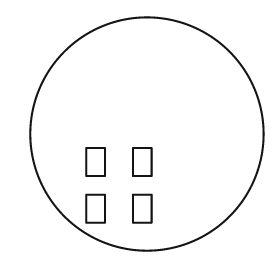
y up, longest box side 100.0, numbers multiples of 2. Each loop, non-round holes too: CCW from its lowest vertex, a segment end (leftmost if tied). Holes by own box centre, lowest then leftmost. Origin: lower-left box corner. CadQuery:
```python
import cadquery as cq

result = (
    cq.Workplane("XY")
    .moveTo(50.0, 50.0)
    .circle(50.0)
    .moveTo(24.0, 12.0)
    .lineTo(32.0, 12.0)
    .lineTo(32.0, 24.0)
    .lineTo(24.0, 24.0)
    .close()
    .moveTo(44.0, 12.0)
    .lineTo(52.0, 12.0)
    .lineTo(52.0, 24.0)
    .lineTo(44.0, 24.0)
    .close()
    .moveTo(24.0, 32.0)
    .lineTo(32.0, 32.0)
    .lineTo(32.0, 44.0)
    .lineTo(24.0, 44.0)
    .close()
    .moveTo(44.0, 32.0)
    .lineTo(52.0, 32.0)
    .lineTo(52.0, 44.0)
    .lineTo(44.0, 44.0)
    .close()
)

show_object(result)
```